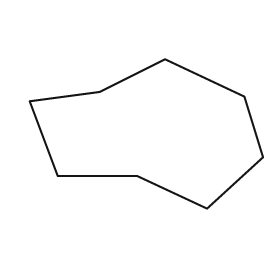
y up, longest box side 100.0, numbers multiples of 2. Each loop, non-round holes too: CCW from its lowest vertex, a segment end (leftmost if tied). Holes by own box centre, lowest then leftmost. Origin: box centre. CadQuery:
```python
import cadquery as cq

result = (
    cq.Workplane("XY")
    .moveTo(26.0, -32.0)
    .lineTo(50.0, -10.0)
    .lineTo(42.0, 16.0)
    .lineTo(8.0, 32.0)
    .lineTo(-20.0, 18.0)
    .lineTo(-50.0, 14.0)
    .lineTo(-38.0, -18.0)
    .lineTo(-4.0, -18.0)
    .close()
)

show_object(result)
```